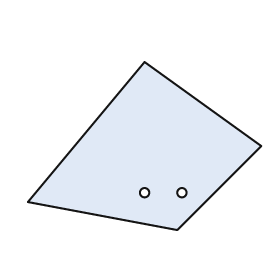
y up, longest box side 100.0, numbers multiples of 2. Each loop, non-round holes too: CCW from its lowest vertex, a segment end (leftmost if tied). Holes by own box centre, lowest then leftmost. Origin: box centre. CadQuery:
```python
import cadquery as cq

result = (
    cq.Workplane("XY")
    .moveTo(14.0, -36.0)
    .lineTo(50.0, 0.0)
    .lineTo(0.0, 36.0)
    .lineTo(-50.0, -24.0)
    .close()
    .moveTo(0.0, -20.0)
    .circle(2.0)
    .moveTo(16.0, -20.0)
    .circle(2.0)
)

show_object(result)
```